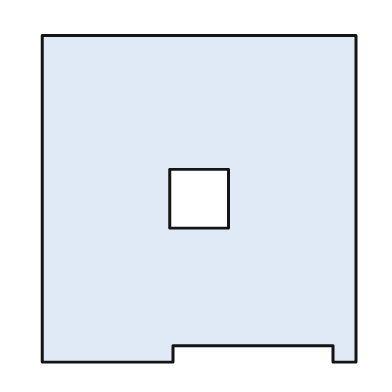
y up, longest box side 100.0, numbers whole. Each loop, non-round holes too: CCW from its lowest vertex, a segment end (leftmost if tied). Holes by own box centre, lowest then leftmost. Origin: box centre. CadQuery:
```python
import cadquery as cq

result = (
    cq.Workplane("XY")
    .moveTo(-48.0, -50.0)
    .lineTo(-8.0, -50.0)
    .lineTo(-8.0, -45.0)
    .lineTo(41.0, -45.0)
    .lineTo(41.0, -50.0)
    .lineTo(48.0, -50.0)
    .lineTo(48.0, 50.0)
    .lineTo(-48.0, 50.0)
    .close()
    .moveTo(-9.0, -9.0)
    .lineTo(9.0, -9.0)
    .lineTo(9.0, 9.0)
    .lineTo(-9.0, 9.0)
    .close()
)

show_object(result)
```